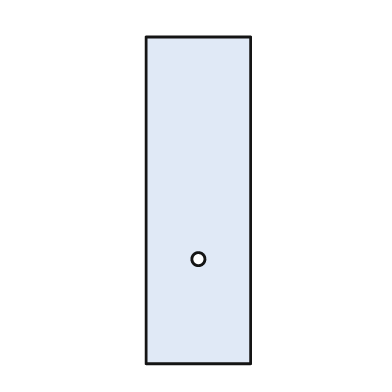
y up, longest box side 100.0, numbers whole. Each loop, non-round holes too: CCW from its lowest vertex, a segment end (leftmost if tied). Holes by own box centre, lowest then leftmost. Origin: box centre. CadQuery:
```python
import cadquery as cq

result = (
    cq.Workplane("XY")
    .moveTo(-16.0, -50.0)
    .lineTo(16.0, -50.0)
    .lineTo(16.0, 50.0)
    .lineTo(-16.0, 50.0)
    .close()
    .moveTo(0.0, -18.0)
    .circle(2.0)
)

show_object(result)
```